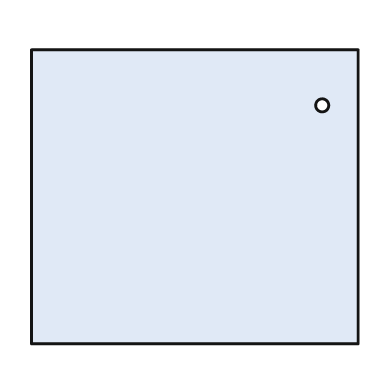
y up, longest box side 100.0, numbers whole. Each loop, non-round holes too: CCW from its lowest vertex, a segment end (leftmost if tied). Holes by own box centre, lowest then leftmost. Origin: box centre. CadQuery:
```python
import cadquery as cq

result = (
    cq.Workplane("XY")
    .moveTo(-50.0, -45.0)
    .lineTo(50.0, -45.0)
    .lineTo(50.0, 45.0)
    .lineTo(-50.0, 45.0)
    .close()
    .moveTo(39.0, 28.0)
    .circle(2.0)
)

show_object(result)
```